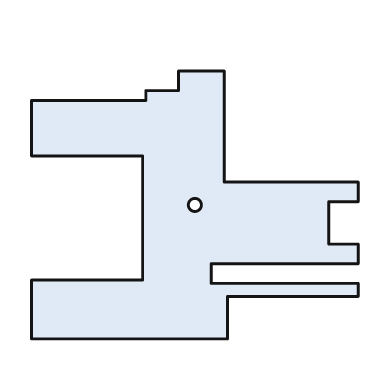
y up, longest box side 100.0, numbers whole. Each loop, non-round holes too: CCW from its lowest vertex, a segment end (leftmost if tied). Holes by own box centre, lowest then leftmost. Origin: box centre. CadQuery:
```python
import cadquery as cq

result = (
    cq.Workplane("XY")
    .moveTo(-50.0, -41.0)
    .lineTo(10.0, -41.0)
    .lineTo(10.0, -28.0)
    .lineTo(50.0, -28.0)
    .lineTo(50.0, -24.0)
    .lineTo(5.0, -24.0)
    .lineTo(5.0, -18.0)
    .lineTo(50.0, -18.0)
    .lineTo(50.0, -12.0)
    .lineTo(41.0, -12.0)
    .lineTo(41.0, 1.0)
    .lineTo(50.0, 1.0)
    .lineTo(50.0, 7.0)
    .lineTo(9.0, 7.0)
    .lineTo(9.0, 41.0)
    .lineTo(-5.0, 41.0)
    .lineTo(-5.0, 35.0)
    .lineTo(-15.0, 35.0)
    .lineTo(-15.0, 32.0)
    .lineTo(-50.0, 32.0)
    .lineTo(-50.0, 15.0)
    .lineTo(-16.0, 15.0)
    .lineTo(-16.0, -23.0)
    .lineTo(-50.0, -23.0)
    .close()
    .moveTo(0.0, 0.0)
    .circle(2.0)
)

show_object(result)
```